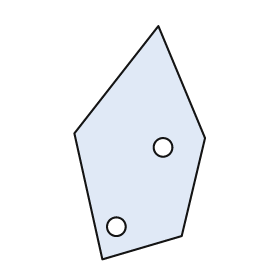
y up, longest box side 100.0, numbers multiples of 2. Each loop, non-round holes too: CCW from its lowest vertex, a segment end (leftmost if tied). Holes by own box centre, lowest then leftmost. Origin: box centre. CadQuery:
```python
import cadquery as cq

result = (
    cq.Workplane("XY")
    .moveTo(-16.0, -50.0)
    .lineTo(18.0, -40.0)
    .lineTo(28.0, 2.0)
    .lineTo(8.0, 50.0)
    .lineTo(-28.0, 4.0)
    .close()
    .moveTo(-10.0, -36.0)
    .circle(4.0)
    .moveTo(10.0, -2.0)
    .circle(4.0)
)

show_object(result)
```